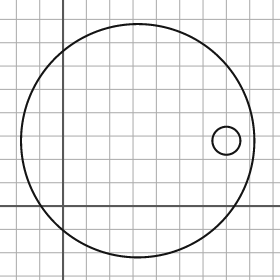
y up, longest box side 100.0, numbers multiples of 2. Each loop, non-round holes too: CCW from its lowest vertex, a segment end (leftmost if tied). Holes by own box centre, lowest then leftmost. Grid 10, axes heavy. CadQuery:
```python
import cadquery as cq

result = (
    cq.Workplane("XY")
    .moveTo(32.0, 28.0)
    .circle(50.0)
    .moveTo(70.0, 28.0)
    .circle(6.0)
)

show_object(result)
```